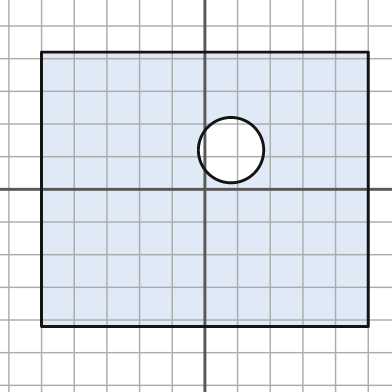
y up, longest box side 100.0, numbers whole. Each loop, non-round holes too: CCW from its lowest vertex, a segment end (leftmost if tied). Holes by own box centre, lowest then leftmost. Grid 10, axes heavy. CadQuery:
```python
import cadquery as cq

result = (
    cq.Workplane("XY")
    .moveTo(-50.0, -42.0)
    .lineTo(50.0, -42.0)
    .lineTo(50.0, 42.0)
    .lineTo(-50.0, 42.0)
    .close()
    .moveTo(8.0, 12.0)
    .circle(10.0)
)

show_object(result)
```